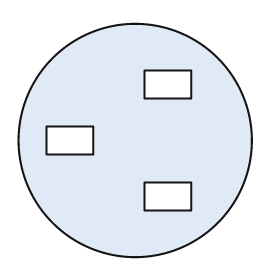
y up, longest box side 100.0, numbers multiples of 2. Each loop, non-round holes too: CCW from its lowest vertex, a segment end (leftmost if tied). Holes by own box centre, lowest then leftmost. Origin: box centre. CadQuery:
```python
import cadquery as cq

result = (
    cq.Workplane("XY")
    .moveTo(0.0, 0.0)
    .circle(50.0)
    .moveTo(4.0, -30.0)
    .lineTo(24.0, -30.0)
    .lineTo(24.0, -18.0)
    .lineTo(4.0, -18.0)
    .close()
    .moveTo(-38.0, -6.0)
    .lineTo(-18.0, -6.0)
    .lineTo(-18.0, 6.0)
    .lineTo(-38.0, 6.0)
    .close()
    .moveTo(4.0, 18.0)
    .lineTo(24.0, 18.0)
    .lineTo(24.0, 30.0)
    .lineTo(4.0, 30.0)
    .close()
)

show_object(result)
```